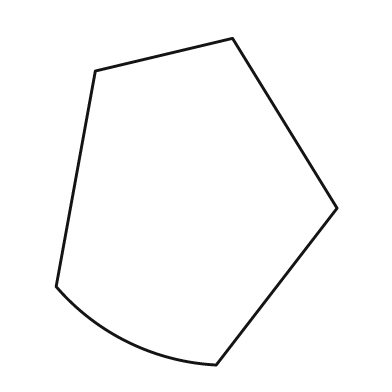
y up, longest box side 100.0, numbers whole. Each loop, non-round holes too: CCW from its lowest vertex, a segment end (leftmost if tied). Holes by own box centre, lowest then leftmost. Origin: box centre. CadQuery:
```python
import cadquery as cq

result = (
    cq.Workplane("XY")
    .moveTo(6.0, -50.0)
    .lineTo(43.0, -2.0)
    .lineTo(11.0, 50.0)
    .lineTo(-31.0, 40.0)
    .lineTo(-43.0, -26.0)
    .threePointArc((-21.0, -43.0), (6.0, -50.0))
    .close()
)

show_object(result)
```